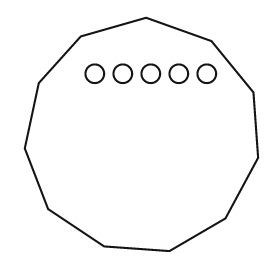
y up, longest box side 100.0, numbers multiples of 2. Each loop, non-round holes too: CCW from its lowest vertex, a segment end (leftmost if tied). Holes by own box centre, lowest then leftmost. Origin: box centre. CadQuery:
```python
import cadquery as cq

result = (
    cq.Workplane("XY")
    .moveTo(12.0, -50.0)
    .lineTo(36.0, -36.0)
    .lineTo(50.0, -10.0)
    .lineTo(48.0, 18.0)
    .lineTo(30.0, 40.0)
    .lineTo(2.0, 50.0)
    .lineTo(-26.0, 42.0)
    .lineTo(-44.0, 22.0)
    .lineTo(-50.0, -6.0)
    .lineTo(-40.0, -32.0)
    .lineTo(-16.0, -48.0)
    .close()
    .moveTo(-20.0, 26.0)
    .circle(4.0)
    .moveTo(-8.0, 26.0)
    .circle(4.0)
    .moveTo(4.0, 26.0)
    .circle(4.0)
    .moveTo(16.0, 26.0)
    .circle(4.0)
    .moveTo(28.0, 26.0)
    .circle(4.0)
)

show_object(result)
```